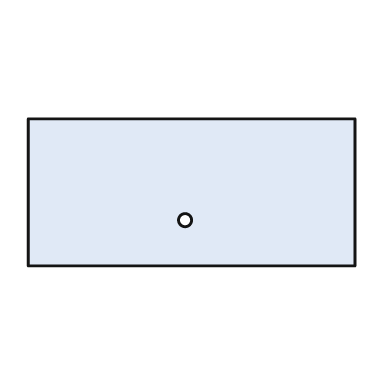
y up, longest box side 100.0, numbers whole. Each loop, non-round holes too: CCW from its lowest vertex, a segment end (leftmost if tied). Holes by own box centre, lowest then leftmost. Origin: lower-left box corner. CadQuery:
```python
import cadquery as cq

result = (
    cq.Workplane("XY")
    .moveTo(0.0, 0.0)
    .lineTo(100.0, 0.0)
    .lineTo(100.0, 45.0)
    .lineTo(0.0, 45.0)
    .close()
    .moveTo(48.0, 14.0)
    .circle(2.0)
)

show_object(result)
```